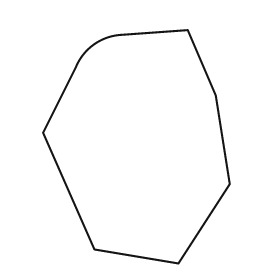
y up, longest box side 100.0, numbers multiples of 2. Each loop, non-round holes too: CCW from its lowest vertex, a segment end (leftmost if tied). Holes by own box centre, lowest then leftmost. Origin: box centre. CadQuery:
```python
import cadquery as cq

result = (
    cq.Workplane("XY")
    .moveTo(18.0, -50.0)
    .lineTo(40.0, -16.0)
    .lineTo(34.0, 22.0)
    .lineTo(22.0, 50.0)
    .lineTo(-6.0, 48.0)
    .threePointArc((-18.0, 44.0), (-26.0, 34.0))
    .lineTo(-40.0, 6.0)
    .lineTo(-18.0, -44.0)
    .close()
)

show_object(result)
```